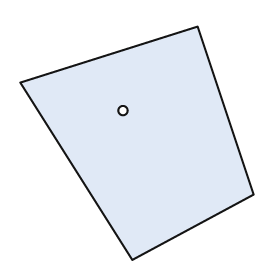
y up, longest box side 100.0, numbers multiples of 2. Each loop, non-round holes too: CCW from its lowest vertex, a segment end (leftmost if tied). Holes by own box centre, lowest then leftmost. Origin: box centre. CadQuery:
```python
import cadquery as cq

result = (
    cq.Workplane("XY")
    .moveTo(-2.0, -50.0)
    .lineTo(50.0, -22.0)
    .lineTo(26.0, 50.0)
    .lineTo(-50.0, 26.0)
    .close()
    .moveTo(-6.0, 14.0)
    .circle(2.0)
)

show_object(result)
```